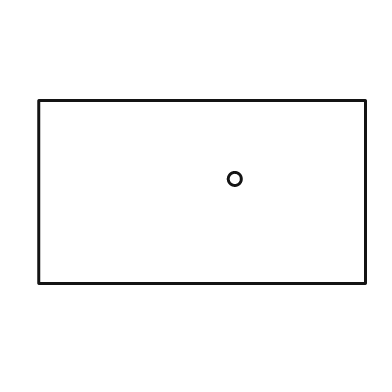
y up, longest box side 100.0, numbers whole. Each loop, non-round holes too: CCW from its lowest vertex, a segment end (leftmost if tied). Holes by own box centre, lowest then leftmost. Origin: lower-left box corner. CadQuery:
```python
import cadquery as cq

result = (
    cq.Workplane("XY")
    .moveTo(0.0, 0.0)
    .lineTo(100.0, 0.0)
    .lineTo(100.0, 56.0)
    .lineTo(0.0, 56.0)
    .close()
    .moveTo(60.0, 32.0)
    .circle(2.0)
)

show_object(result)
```